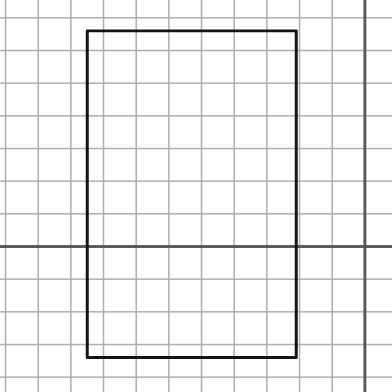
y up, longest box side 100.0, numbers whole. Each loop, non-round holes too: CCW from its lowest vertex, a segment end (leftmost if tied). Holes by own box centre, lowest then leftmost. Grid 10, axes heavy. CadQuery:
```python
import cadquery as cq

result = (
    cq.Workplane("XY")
    .moveTo(-85.0, -34.0)
    .lineTo(-21.0, -34.0)
    .lineTo(-21.0, 66.0)
    .lineTo(-85.0, 66.0)
    .close()
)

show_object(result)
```